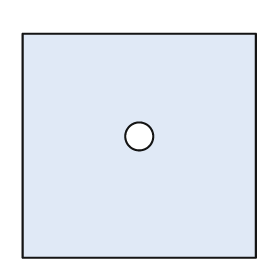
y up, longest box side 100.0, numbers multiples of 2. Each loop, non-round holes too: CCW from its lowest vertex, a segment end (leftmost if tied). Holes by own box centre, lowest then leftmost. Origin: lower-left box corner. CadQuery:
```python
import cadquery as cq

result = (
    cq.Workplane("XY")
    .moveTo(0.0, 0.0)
    .lineTo(100.0, 0.0)
    .lineTo(100.0, 96.0)
    .lineTo(0.0, 96.0)
    .close()
    .moveTo(50.0, 52.0)
    .circle(6.0)
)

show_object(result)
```